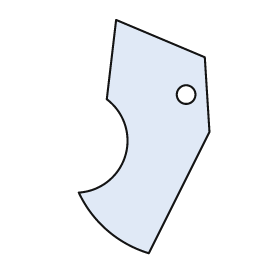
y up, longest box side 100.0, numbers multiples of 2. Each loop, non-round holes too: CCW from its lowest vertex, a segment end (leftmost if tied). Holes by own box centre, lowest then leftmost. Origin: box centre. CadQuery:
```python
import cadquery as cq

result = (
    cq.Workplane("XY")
    .moveTo(2.0, -50.0)
    .lineTo(28.0, 2.0)
    .lineTo(26.0, 34.0)
    .lineTo(-12.0, 50.0)
    .lineTo(-16.0, 16.0)
    .threePointArc((-8.0, -8.0), (-28.0, -24.0))
    .threePointArc((-16.0, -40.0), (2.0, -50.0))
    .close()
    .moveTo(18.0, 18.0)
    .circle(4.0)
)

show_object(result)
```